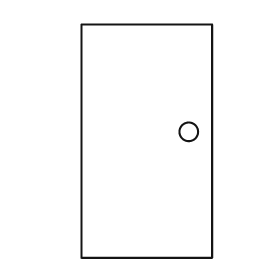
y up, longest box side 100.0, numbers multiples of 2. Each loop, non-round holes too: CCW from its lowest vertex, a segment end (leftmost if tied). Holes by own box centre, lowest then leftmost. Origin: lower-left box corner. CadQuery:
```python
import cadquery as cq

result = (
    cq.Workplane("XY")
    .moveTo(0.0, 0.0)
    .lineTo(56.0, 0.0)
    .lineTo(56.0, 100.0)
    .lineTo(0.0, 100.0)
    .close()
    .moveTo(46.0, 54.0)
    .circle(4.0)
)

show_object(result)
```